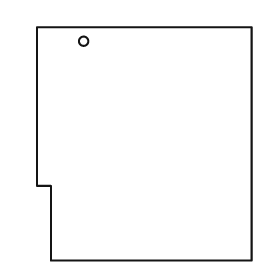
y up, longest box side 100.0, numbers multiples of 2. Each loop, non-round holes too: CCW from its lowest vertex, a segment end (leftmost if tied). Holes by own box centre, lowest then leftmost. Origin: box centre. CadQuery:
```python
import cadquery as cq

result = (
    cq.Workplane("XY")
    .moveTo(-40.0, -50.0)
    .lineTo(46.0, -50.0)
    .lineTo(46.0, 50.0)
    .lineTo(-46.0, 50.0)
    .lineTo(-46.0, -18.0)
    .lineTo(-40.0, -18.0)
    .close()
    .moveTo(-26.0, 44.0)
    .circle(2.0)
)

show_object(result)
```